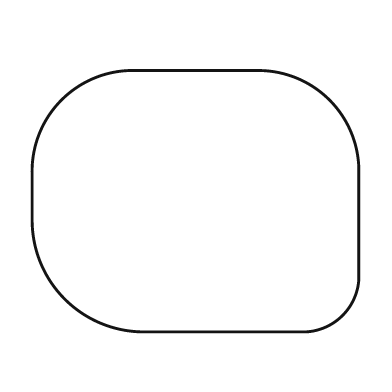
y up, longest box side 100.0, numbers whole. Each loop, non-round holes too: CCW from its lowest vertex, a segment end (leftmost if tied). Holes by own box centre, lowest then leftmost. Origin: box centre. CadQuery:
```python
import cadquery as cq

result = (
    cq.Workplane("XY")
    .moveTo(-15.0, -40.0)
    .lineTo(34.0, -40.0)
    .threePointArc((45.0, -35.0), (50.0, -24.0))
    .lineTo(50.0, 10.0)
    .threePointArc((41.0, 31.0), (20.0, 40.0))
    .lineTo(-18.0, 40.0)
    .threePointArc((-41.0, 31.0), (-50.0, 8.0))
    .lineTo(-50.0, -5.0)
    .threePointArc((-40.0, -30.0), (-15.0, -40.0))
    .close()
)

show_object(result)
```